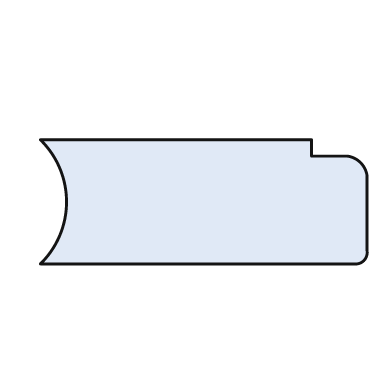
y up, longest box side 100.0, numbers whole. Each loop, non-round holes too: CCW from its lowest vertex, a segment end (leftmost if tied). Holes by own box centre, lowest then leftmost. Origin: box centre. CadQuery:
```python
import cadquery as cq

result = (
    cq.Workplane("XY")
    .moveTo(-50.0, -19.0)
    .lineTo(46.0, -19.0)
    .threePointArc((49.0, -18.0), (50.0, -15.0))
    .lineTo(50.0, 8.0)
    .threePointArc((48.0, 12.0), (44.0, 14.0))
    .lineTo(33.0, 14.0)
    .lineTo(33.0, 19.0)
    .lineTo(-50.0, 19.0)
    .threePointArc((-42.0, 0.0), (-50.0, -19.0))
    .close()
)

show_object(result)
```